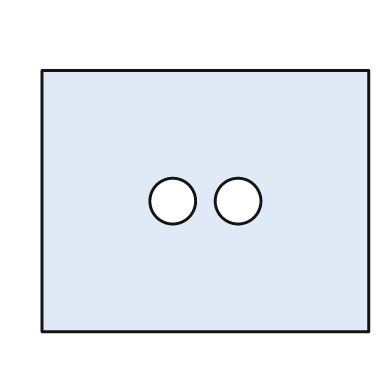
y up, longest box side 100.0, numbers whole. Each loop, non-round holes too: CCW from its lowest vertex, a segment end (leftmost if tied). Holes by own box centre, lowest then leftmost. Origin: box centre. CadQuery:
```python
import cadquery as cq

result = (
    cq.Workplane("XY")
    .moveTo(-50.0, -40.0)
    .lineTo(50.0, -40.0)
    .lineTo(50.0, 40.0)
    .lineTo(-50.0, 40.0)
    .close()
    .moveTo(-10.0, 0.0)
    .circle(7.0)
    .moveTo(10.0, 0.0)
    .circle(7.0)
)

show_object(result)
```